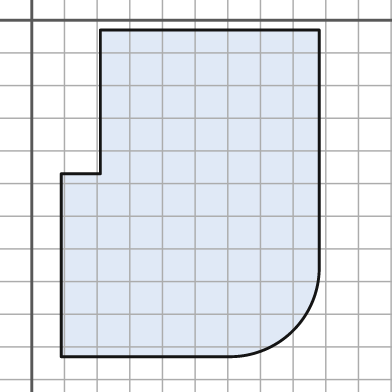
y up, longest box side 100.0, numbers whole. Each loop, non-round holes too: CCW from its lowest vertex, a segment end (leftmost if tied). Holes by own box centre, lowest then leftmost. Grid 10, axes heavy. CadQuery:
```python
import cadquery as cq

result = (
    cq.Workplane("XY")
    .moveTo(9.0, -103.0)
    .lineTo(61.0, -103.0)
    .threePointArc((80.0, -95.0), (88.0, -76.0))
    .lineTo(88.0, -3.0)
    .lineTo(21.0, -3.0)
    .lineTo(21.0, -47.0)
    .lineTo(9.0, -47.0)
    .close()
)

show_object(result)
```